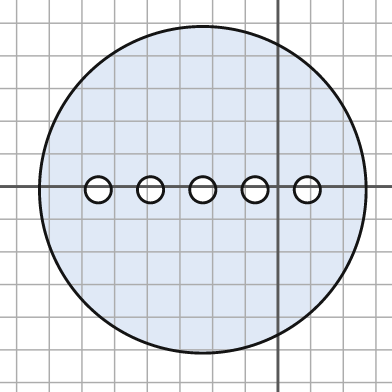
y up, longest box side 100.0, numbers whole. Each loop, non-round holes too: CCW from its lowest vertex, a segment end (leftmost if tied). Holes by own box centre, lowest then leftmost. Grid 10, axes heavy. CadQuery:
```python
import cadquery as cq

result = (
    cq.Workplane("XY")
    .moveTo(-23.0, -1.0)
    .circle(50.0)
    .moveTo(-55.0, -1.0)
    .circle(4.0)
    .moveTo(-39.0, -1.0)
    .circle(4.0)
    .moveTo(-23.0, -1.0)
    .circle(4.0)
    .moveTo(-7.0, -1.0)
    .circle(4.0)
    .moveTo(9.0, -1.0)
    .circle(4.0)
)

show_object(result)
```